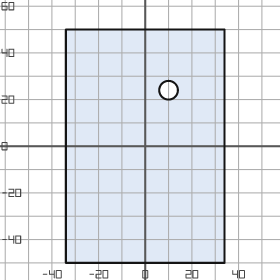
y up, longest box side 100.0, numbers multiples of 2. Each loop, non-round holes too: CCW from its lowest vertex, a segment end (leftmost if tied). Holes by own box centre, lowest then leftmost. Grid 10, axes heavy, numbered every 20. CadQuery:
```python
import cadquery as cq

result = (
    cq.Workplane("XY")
    .moveTo(-34.0, -50.0)
    .lineTo(34.0, -50.0)
    .lineTo(34.0, 50.0)
    .lineTo(-34.0, 50.0)
    .close()
    .moveTo(10.0, 24.0)
    .circle(4.0)
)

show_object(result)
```